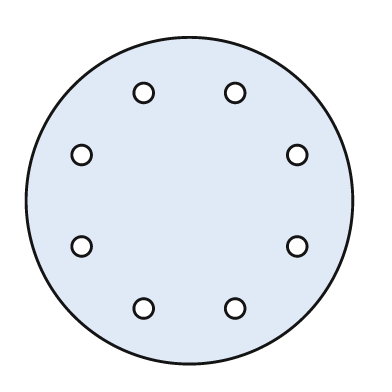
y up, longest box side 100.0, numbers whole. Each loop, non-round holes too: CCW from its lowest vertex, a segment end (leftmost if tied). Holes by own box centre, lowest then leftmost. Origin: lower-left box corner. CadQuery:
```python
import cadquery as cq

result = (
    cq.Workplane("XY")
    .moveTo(50.0, 50.0)
    .circle(50.0)
    .moveTo(36.0, 17.0)
    .circle(3.0)
    .moveTo(64.0, 17.0)
    .circle(3.0)
    .moveTo(17.0, 36.0)
    .circle(3.0)
    .moveTo(83.0, 36.0)
    .circle(3.0)
    .moveTo(17.0, 64.0)
    .circle(3.0)
    .moveTo(83.0, 64.0)
    .circle(3.0)
    .moveTo(36.0, 83.0)
    .circle(3.0)
    .moveTo(64.0, 83.0)
    .circle(3.0)
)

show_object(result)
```